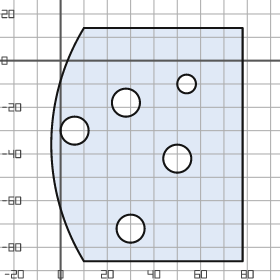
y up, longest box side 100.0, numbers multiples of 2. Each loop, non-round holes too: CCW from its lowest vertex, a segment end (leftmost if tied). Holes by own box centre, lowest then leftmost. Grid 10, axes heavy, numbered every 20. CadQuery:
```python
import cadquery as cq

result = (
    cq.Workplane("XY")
    .moveTo(10.0, -86.0)
    .lineTo(78.0, -86.0)
    .lineTo(78.0, 14.0)
    .lineTo(10.0, 14.0)
    .threePointArc((-4.0, -36.0), (10.0, -86.0))
    .close()
    .moveTo(30.0, -72.0)
    .circle(6.0)
    .moveTo(50.0, -42.0)
    .circle(6.0)
    .moveTo(6.0, -30.0)
    .circle(6.0)
    .moveTo(28.0, -18.0)
    .circle(6.0)
    .moveTo(54.0, -10.0)
    .circle(4.0)
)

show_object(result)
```